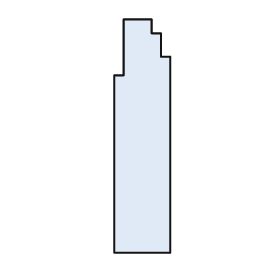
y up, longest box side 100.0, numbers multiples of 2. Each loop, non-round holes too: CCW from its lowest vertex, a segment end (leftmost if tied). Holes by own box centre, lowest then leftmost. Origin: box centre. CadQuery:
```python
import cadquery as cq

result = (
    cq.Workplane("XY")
    .moveTo(-12.0, -50.0)
    .lineTo(12.0, -50.0)
    .lineTo(12.0, 34.0)
    .lineTo(8.0, 34.0)
    .lineTo(8.0, 44.0)
    .lineTo(4.0, 44.0)
    .lineTo(4.0, 50.0)
    .lineTo(-8.0, 50.0)
    .lineTo(-8.0, 26.0)
    .lineTo(-12.0, 26.0)
    .close()
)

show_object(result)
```